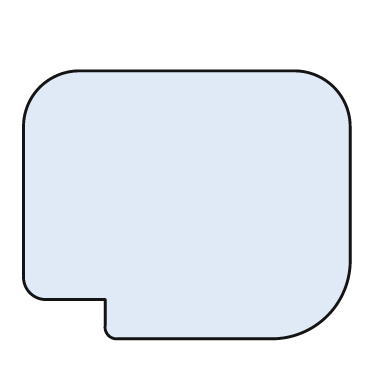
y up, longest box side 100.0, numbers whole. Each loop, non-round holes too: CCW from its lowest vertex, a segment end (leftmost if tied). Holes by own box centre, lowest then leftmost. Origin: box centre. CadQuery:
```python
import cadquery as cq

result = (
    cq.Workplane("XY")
    .moveTo(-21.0, -41.0)
    .lineTo(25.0, -41.0)
    .threePointArc((43.0, -34.0), (50.0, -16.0))
    .lineTo(50.0, 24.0)
    .threePointArc((45.0, 36.0), (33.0, 41.0))
    .lineTo(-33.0, 41.0)
    .threePointArc((-45.0, 36.0), (-50.0, 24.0))
    .lineTo(-50.0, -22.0)
    .threePointArc((-48.0, -27.0), (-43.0, -29.0))
    .lineTo(-25.0, -29.0)
    .lineTo(-25.0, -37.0)
    .threePointArc((-24.0, -40.0), (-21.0, -41.0))
    .close()
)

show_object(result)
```